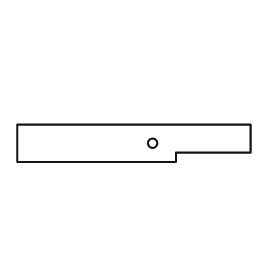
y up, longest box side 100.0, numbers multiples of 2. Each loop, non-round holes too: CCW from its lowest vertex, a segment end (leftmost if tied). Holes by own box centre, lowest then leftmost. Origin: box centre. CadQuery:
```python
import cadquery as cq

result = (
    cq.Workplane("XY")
    .moveTo(-50.0, -8.0)
    .lineTo(18.0, -8.0)
    .lineTo(18.0, -4.0)
    .lineTo(50.0, -4.0)
    .lineTo(50.0, 8.0)
    .lineTo(-50.0, 8.0)
    .close()
    .moveTo(8.0, 0.0)
    .circle(2.0)
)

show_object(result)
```